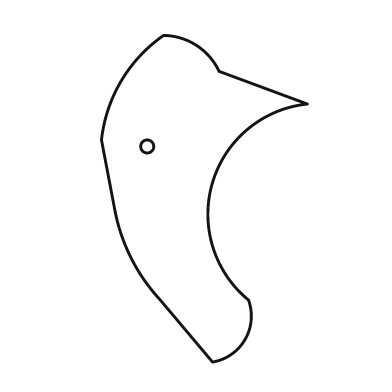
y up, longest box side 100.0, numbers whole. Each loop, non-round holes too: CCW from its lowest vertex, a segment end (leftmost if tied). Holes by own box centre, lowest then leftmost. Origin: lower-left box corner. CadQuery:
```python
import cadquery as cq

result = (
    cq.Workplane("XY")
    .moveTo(34.0, 0.0)
    .threePointArc((44.0, 7.0), (45.0, 19.0))
    .threePointArc((34.0, 55.0), (63.0, 79.0))
    .lineTo(36.0, 89.0)
    .threePointArc((29.0, 97.0), (19.0, 100.0))
    .threePointArc((6.0, 86.0), (0.0, 68.0))
    .lineTo(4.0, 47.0)
    .threePointArc((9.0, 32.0), (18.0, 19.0))
    .close()
    .moveTo(14.0, 66.0)
    .circle(2.0)
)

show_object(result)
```